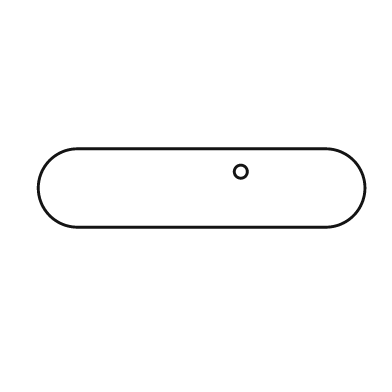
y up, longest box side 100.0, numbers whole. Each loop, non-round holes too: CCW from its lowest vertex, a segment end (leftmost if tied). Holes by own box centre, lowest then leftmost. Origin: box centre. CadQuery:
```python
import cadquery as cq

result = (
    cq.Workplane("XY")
    .moveTo(-38.0, -12.0)
    .lineTo(38.0, -12.0)
    .threePointArc((50.0, 0.0), (38.0, 12.0))
    .lineTo(-38.0, 12.0)
    .threePointArc((-50.0, 0.0), (-38.0, -12.0))
    .close()
    .moveTo(12.0, 5.0)
    .circle(2.0)
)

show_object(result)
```